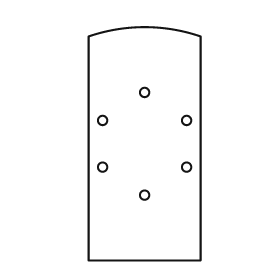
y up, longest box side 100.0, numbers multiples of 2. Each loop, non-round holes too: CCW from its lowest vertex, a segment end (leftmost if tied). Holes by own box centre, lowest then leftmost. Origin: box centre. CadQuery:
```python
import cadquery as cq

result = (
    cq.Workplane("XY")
    .moveTo(-24.0, -50.0)
    .lineTo(24.0, -50.0)
    .lineTo(24.0, 46.0)
    .threePointArc((0.0, 50.0), (-24.0, 46.0))
    .close()
    .moveTo(0.0, -22.0)
    .circle(2.0)
    .moveTo(-18.0, -10.0)
    .circle(2.0)
    .moveTo(18.0, -10.0)
    .circle(2.0)
    .moveTo(-18.0, 10.0)
    .circle(2.0)
    .moveTo(18.0, 10.0)
    .circle(2.0)
    .moveTo(0.0, 22.0)
    .circle(2.0)
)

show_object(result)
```